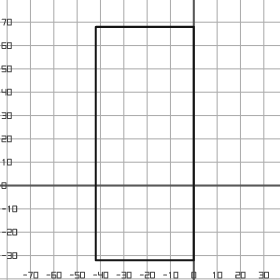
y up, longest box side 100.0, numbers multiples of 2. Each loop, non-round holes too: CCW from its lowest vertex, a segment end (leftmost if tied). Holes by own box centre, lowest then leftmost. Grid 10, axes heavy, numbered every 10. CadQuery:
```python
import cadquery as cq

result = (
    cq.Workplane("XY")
    .moveTo(-42.0, -32.0)
    .lineTo(0.0, -32.0)
    .lineTo(0.0, 68.0)
    .lineTo(-42.0, 68.0)
    .close()
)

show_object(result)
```